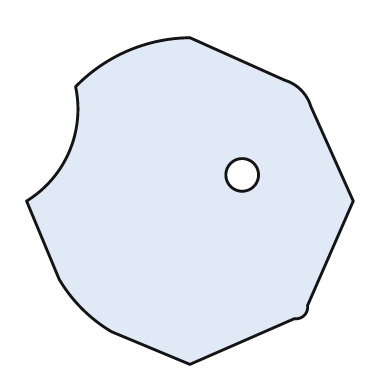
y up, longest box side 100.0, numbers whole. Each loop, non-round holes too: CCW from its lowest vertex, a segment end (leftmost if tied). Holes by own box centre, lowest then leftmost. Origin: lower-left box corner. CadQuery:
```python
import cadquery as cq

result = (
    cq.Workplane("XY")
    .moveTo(50.0, 0.0)
    .lineTo(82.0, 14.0)
    .threePointArc((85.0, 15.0), (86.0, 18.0))
    .lineTo(100.0, 50.0)
    .lineTo(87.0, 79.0)
    .threePointArc((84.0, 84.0), (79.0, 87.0))
    .lineTo(50.0, 100.0)
    .threePointArc((31.0, 96.0), (15.0, 85.0))
    .threePointArc((13.0, 65.0), (0.0, 50.0))
    .lineTo(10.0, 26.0)
    .threePointArc((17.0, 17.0), (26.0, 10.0))
    .close()
    .moveTo(66.0, 58.0)
    .circle(5.0)
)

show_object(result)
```